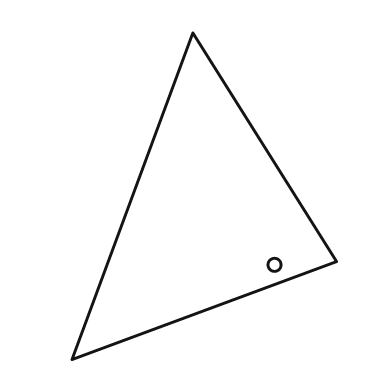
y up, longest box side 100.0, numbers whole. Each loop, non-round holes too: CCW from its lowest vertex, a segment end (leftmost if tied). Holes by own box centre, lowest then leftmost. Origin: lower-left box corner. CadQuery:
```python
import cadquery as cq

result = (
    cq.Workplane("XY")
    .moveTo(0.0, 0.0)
    .lineTo(81.0, 30.0)
    .lineTo(37.0, 100.0)
    .close()
    .moveTo(62.0, 29.0)
    .circle(2.0)
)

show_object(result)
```